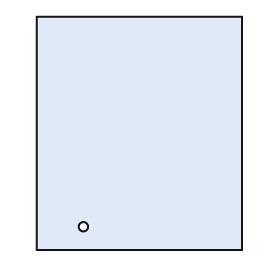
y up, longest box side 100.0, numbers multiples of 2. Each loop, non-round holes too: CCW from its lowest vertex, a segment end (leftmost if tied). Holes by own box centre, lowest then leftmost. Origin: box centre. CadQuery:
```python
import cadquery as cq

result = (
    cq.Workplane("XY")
    .moveTo(-44.0, -50.0)
    .lineTo(44.0, -50.0)
    .lineTo(44.0, 50.0)
    .lineTo(-44.0, 50.0)
    .close()
    .moveTo(-24.0, -40.0)
    .circle(2.0)
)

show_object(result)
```